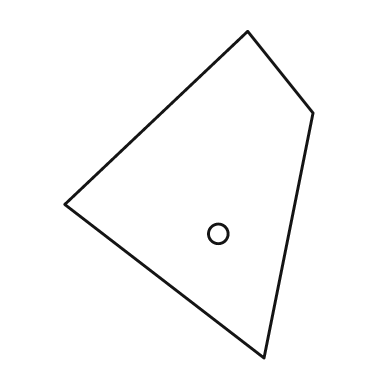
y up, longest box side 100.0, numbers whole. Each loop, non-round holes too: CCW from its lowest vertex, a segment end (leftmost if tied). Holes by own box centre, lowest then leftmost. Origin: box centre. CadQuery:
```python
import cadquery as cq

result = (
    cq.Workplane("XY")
    .moveTo(23.0, -50.0)
    .lineTo(38.0, 25.0)
    .lineTo(18.0, 50.0)
    .lineTo(-38.0, -3.0)
    .close()
    .moveTo(9.0, -12.0)
    .circle(3.0)
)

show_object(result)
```